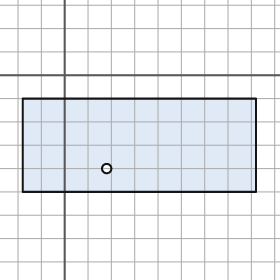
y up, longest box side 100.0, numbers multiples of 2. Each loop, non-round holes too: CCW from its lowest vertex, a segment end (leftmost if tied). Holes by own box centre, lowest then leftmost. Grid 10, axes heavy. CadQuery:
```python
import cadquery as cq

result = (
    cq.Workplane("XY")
    .moveTo(-18.0, -50.0)
    .lineTo(82.0, -50.0)
    .lineTo(82.0, -10.0)
    .lineTo(-18.0, -10.0)
    .close()
    .moveTo(18.0, -40.0)
    .circle(2.0)
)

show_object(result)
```